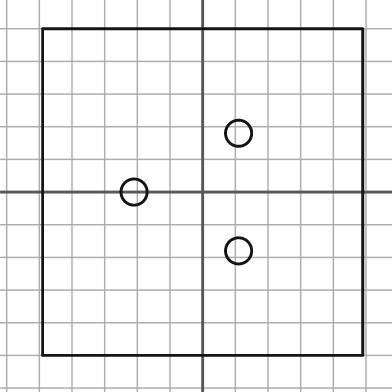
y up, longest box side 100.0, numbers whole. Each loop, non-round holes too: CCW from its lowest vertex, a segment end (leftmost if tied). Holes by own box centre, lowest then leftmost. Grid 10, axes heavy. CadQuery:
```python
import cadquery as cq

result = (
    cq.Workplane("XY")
    .moveTo(-49.0, -50.0)
    .lineTo(49.0, -50.0)
    .lineTo(49.0, 50.0)
    .lineTo(-49.0, 50.0)
    .close()
    .moveTo(11.0, -18.0)
    .circle(4.0)
    .moveTo(-21.0, 0.0)
    .circle(4.0)
    .moveTo(11.0, 18.0)
    .circle(4.0)
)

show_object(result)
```